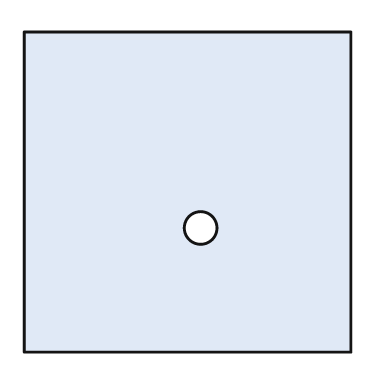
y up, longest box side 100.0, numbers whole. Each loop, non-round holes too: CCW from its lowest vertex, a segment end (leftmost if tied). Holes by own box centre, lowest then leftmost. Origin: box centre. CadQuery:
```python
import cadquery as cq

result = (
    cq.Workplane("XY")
    .moveTo(-50.0, -49.0)
    .lineTo(50.0, -49.0)
    .lineTo(50.0, 49.0)
    .lineTo(-50.0, 49.0)
    .close()
    .moveTo(4.0, -11.0)
    .circle(5.0)
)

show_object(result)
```